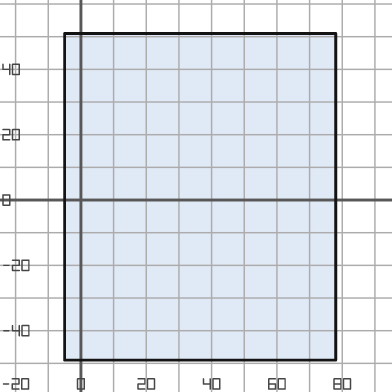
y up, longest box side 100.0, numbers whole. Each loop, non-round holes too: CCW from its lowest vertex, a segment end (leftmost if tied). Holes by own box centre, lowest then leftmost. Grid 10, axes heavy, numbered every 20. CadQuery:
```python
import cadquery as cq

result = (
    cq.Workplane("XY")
    .moveTo(-5.0, -49.0)
    .lineTo(78.0, -49.0)
    .lineTo(78.0, 51.0)
    .lineTo(-5.0, 51.0)
    .close()
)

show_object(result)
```